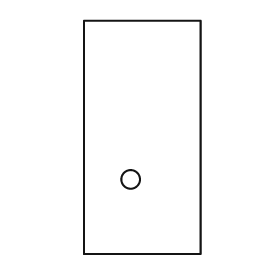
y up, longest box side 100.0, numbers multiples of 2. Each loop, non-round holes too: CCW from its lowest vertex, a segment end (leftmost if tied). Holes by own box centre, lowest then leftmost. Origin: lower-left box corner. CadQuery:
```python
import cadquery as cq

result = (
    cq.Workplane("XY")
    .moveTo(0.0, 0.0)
    .lineTo(50.0, 0.0)
    .lineTo(50.0, 100.0)
    .lineTo(0.0, 100.0)
    .close()
    .moveTo(20.0, 32.0)
    .circle(4.0)
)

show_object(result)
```